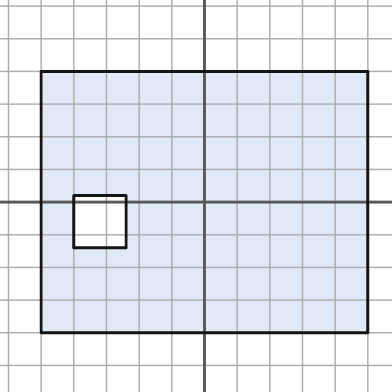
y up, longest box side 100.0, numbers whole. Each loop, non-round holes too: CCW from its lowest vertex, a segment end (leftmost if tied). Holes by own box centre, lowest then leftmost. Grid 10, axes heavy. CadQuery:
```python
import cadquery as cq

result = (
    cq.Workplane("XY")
    .moveTo(-50.0, -40.0)
    .lineTo(50.0, -40.0)
    .lineTo(50.0, 40.0)
    .lineTo(-50.0, 40.0)
    .close()
    .moveTo(-40.0, -14.0)
    .lineTo(-24.0, -14.0)
    .lineTo(-24.0, 2.0)
    .lineTo(-40.0, 2.0)
    .close()
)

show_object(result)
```